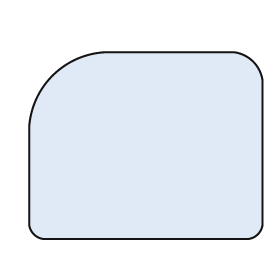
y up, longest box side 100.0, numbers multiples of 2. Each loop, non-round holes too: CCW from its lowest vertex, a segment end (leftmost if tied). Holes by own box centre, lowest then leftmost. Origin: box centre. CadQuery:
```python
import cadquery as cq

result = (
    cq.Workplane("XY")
    .moveTo(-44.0, -40.0)
    .lineTo(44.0, -40.0)
    .threePointArc((48.0, -38.0), (50.0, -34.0))
    .lineTo(50.0, 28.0)
    .threePointArc((46.0, 36.0), (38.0, 40.0))
    .lineTo(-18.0, 40.0)
    .threePointArc((-40.0, 30.0), (-50.0, 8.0))
    .lineTo(-50.0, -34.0)
    .threePointArc((-48.0, -38.0), (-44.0, -40.0))
    .close()
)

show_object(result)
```